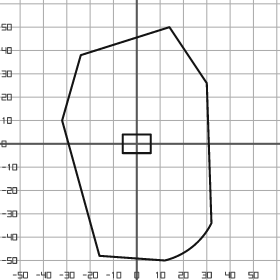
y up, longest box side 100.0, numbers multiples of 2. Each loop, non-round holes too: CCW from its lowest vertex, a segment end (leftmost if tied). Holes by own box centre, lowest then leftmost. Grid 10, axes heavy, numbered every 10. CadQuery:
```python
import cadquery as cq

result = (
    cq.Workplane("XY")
    .moveTo(12.0, -50.0)
    .threePointArc((24.0, -44.0), (32.0, -34.0))
    .lineTo(30.0, 26.0)
    .lineTo(14.0, 50.0)
    .lineTo(-24.0, 38.0)
    .lineTo(-32.0, 10.0)
    .lineTo(-16.0, -48.0)
    .close()
    .moveTo(-6.0, -4.0)
    .lineTo(6.0, -4.0)
    .lineTo(6.0, 4.0)
    .lineTo(-6.0, 4.0)
    .close()
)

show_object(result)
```